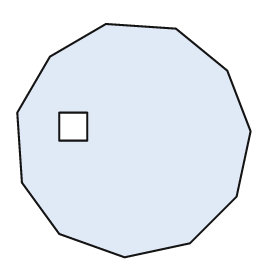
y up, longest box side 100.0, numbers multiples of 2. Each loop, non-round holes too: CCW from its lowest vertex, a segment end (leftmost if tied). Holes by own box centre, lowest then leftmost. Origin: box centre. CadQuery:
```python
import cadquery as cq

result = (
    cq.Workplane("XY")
    .moveTo(-4.0, -50.0)
    .lineTo(24.0, -44.0)
    .lineTo(44.0, -24.0)
    .lineTo(50.0, 4.0)
    .lineTo(40.0, 30.0)
    .lineTo(18.0, 48.0)
    .lineTo(-12.0, 50.0)
    .lineTo(-36.0, 36.0)
    .lineTo(-50.0, 12.0)
    .lineTo(-48.0, -18.0)
    .lineTo(-32.0, -40.0)
    .close()
    .moveTo(-32.0, 0.0)
    .lineTo(-20.0, 0.0)
    .lineTo(-20.0, 12.0)
    .lineTo(-32.0, 12.0)
    .close()
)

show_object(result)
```